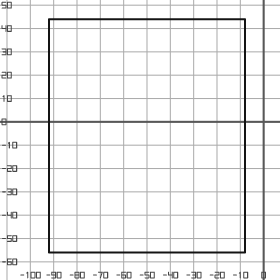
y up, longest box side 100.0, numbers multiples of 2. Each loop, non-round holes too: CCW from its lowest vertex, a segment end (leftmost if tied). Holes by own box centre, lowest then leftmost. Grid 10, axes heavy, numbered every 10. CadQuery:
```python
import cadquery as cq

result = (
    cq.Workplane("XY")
    .moveTo(-92.0, -56.0)
    .lineTo(-8.0, -56.0)
    .lineTo(-8.0, 44.0)
    .lineTo(-92.0, 44.0)
    .close()
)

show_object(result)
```